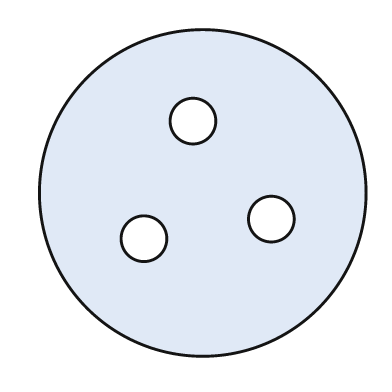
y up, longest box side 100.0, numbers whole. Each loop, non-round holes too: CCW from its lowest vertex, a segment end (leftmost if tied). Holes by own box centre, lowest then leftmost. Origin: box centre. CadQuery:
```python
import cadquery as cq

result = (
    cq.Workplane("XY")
    .moveTo(0.0, 0.0)
    .circle(50.0)
    .moveTo(-18.0, -14.0)
    .circle(7.0)
    .moveTo(21.0, -8.0)
    .circle(7.0)
    .moveTo(-3.0, 22.0)
    .circle(7.0)
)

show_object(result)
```